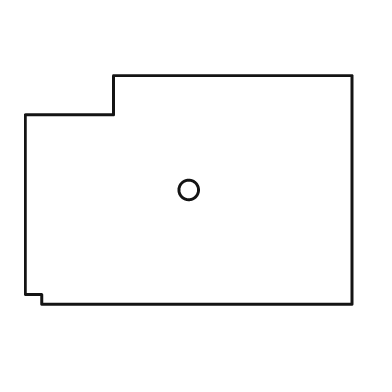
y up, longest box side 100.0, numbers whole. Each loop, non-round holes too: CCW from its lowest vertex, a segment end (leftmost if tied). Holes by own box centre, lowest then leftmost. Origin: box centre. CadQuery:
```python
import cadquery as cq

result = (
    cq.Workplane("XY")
    .moveTo(-45.0, -35.0)
    .lineTo(50.0, -35.0)
    .lineTo(50.0, 35.0)
    .lineTo(-23.0, 35.0)
    .lineTo(-23.0, 23.0)
    .lineTo(-50.0, 23.0)
    .lineTo(-50.0, -32.0)
    .lineTo(-45.0, -32.0)
    .close()
    .moveTo(0.0, 0.0)
    .circle(3.0)
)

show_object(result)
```